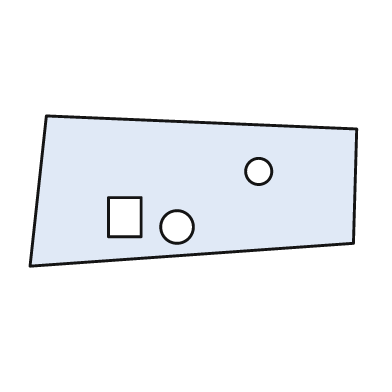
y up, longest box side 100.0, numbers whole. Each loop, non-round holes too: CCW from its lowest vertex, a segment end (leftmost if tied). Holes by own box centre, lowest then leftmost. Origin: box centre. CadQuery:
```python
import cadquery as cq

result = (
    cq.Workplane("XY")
    .moveTo(-50.0, -23.0)
    .lineTo(49.0, -16.0)
    .lineTo(50.0, 19.0)
    .lineTo(-45.0, 23.0)
    .close()
    .moveTo(-5.0, -11.0)
    .circle(5.0)
    .moveTo(-26.0, -14.0)
    .lineTo(-16.0, -14.0)
    .lineTo(-16.0, -2.0)
    .lineTo(-26.0, -2.0)
    .close()
    .moveTo(20.0, 6.0)
    .circle(4.0)
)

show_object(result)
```